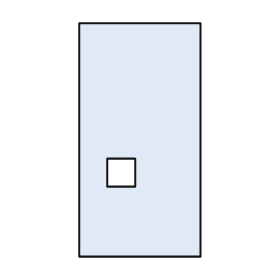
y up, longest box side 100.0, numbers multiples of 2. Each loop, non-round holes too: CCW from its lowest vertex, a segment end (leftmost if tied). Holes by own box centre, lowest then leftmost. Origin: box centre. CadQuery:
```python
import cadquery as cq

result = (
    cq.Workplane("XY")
    .moveTo(-26.0, -50.0)
    .lineTo(26.0, -50.0)
    .lineTo(26.0, 50.0)
    .lineTo(-26.0, 50.0)
    .close()
    .moveTo(-14.0, -20.0)
    .lineTo(-2.0, -20.0)
    .lineTo(-2.0, -8.0)
    .lineTo(-14.0, -8.0)
    .close()
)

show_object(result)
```